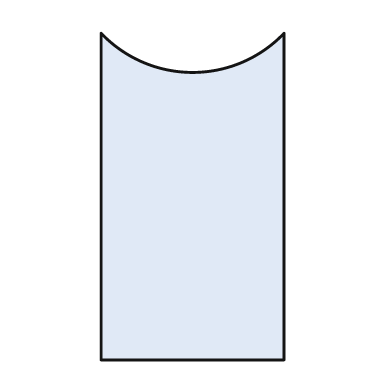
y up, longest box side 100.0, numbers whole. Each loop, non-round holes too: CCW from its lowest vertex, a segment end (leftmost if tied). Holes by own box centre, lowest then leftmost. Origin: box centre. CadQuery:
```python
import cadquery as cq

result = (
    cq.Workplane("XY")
    .moveTo(-28.0, -50.0)
    .lineTo(28.0, -50.0)
    .lineTo(28.0, 50.0)
    .threePointArc((0.0, 38.0), (-28.0, 50.0))
    .close()
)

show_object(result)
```